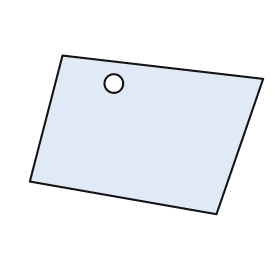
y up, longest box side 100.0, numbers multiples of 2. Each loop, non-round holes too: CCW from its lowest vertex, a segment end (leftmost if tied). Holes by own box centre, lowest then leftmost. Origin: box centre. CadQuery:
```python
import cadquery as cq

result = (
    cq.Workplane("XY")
    .moveTo(30.0, -34.0)
    .lineTo(50.0, 24.0)
    .lineTo(-36.0, 34.0)
    .lineTo(-50.0, -20.0)
    .close()
    .moveTo(-14.0, 22.0)
    .circle(4.0)
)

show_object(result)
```